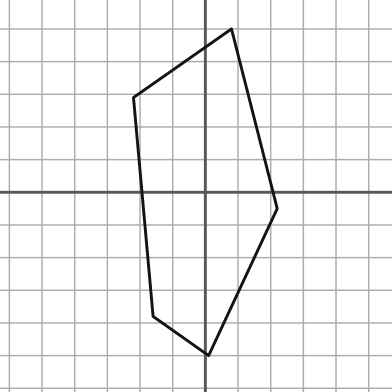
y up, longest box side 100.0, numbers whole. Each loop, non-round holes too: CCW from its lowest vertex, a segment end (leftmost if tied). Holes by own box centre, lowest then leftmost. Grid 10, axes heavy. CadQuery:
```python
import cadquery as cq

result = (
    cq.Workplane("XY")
    .moveTo(1.0, -50.0)
    .lineTo(22.0, -5.0)
    .lineTo(8.0, 50.0)
    .lineTo(-22.0, 29.0)
    .lineTo(-16.0, -38.0)
    .close()
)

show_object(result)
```